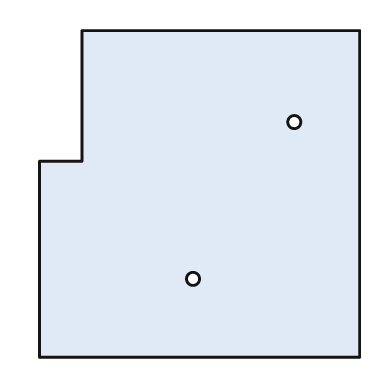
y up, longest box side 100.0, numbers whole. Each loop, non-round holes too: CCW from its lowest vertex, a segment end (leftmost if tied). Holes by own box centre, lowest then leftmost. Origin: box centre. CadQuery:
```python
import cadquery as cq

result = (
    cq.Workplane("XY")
    .moveTo(-49.0, -50.0)
    .lineTo(49.0, -50.0)
    .lineTo(49.0, 50.0)
    .lineTo(-36.0, 50.0)
    .lineTo(-36.0, 10.0)
    .lineTo(-49.0, 10.0)
    .close()
    .moveTo(-2.0, -26.0)
    .circle(2.0)
    .moveTo(29.0, 22.0)
    .circle(2.0)
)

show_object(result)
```